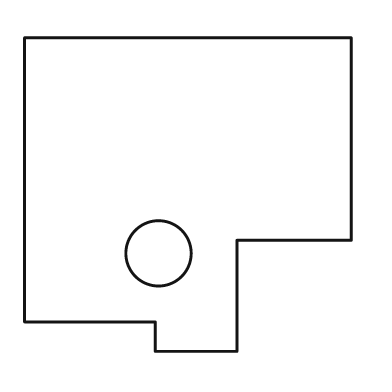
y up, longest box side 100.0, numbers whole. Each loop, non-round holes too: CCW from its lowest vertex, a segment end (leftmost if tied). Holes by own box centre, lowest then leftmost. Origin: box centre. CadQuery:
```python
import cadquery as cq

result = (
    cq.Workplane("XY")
    .moveTo(-10.0, -48.0)
    .lineTo(15.0, -48.0)
    .lineTo(15.0, -14.0)
    .lineTo(50.0, -14.0)
    .lineTo(50.0, 48.0)
    .lineTo(-50.0, 48.0)
    .lineTo(-50.0, -39.0)
    .lineTo(-10.0, -39.0)
    .close()
    .moveTo(-9.0, -18.0)
    .circle(10.0)
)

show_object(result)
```